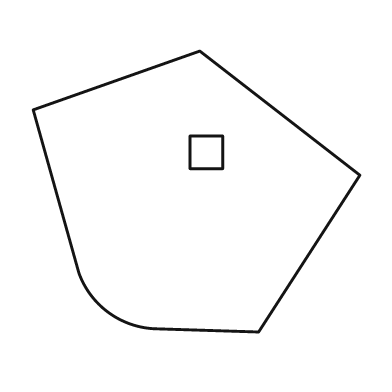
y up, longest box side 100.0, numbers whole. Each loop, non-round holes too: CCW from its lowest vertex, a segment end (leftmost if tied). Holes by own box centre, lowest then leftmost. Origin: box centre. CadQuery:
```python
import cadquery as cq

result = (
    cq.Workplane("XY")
    .moveTo(19.0, -43.0)
    .lineTo(50.0, 5.0)
    .lineTo(1.0, 43.0)
    .lineTo(-50.0, 25.0)
    .lineTo(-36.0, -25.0)
    .threePointArc((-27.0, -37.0), (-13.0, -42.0))
    .close()
    .moveTo(-2.0, 7.0)
    .lineTo(8.0, 7.0)
    .lineTo(8.0, 17.0)
    .lineTo(-2.0, 17.0)
    .close()
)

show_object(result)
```